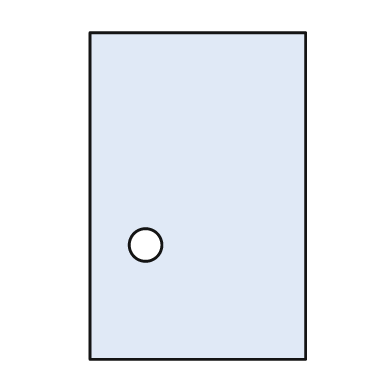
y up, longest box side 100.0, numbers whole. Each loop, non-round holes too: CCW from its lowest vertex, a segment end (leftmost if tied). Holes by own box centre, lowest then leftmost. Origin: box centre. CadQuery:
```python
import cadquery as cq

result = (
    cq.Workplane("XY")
    .moveTo(-33.0, -50.0)
    .lineTo(33.0, -50.0)
    .lineTo(33.0, 50.0)
    .lineTo(-33.0, 50.0)
    .close()
    .moveTo(-16.0, -15.0)
    .circle(5.0)
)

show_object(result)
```